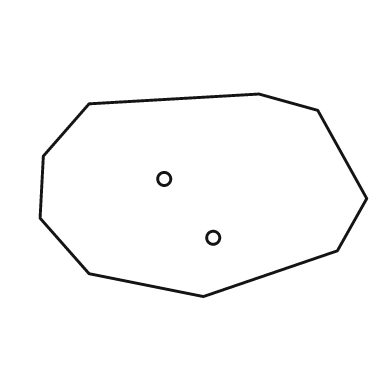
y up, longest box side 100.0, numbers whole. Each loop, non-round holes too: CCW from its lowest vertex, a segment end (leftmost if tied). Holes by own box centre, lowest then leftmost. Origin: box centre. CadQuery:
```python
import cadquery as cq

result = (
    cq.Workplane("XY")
    .moveTo(0.0, -31.0)
    .lineTo(41.0, -17.0)
    .lineTo(50.0, -1.0)
    .lineTo(35.0, 26.0)
    .lineTo(17.0, 31.0)
    .lineTo(-35.0, 28.0)
    .lineTo(-49.0, 12.0)
    .lineTo(-50.0, -7.0)
    .lineTo(-35.0, -24.0)
    .close()
    .moveTo(3.0, -13.0)
    .circle(2.0)
    .moveTo(-12.0, 5.0)
    .circle(2.0)
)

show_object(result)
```